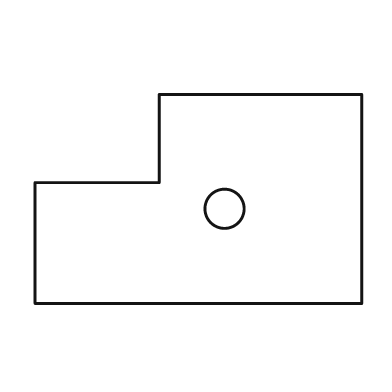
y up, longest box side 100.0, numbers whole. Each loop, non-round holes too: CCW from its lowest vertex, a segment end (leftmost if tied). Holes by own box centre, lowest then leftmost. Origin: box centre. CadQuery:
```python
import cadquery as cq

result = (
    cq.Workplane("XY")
    .moveTo(-50.0, -32.0)
    .lineTo(50.0, -32.0)
    .lineTo(50.0, 32.0)
    .lineTo(-12.0, 32.0)
    .lineTo(-12.0, 5.0)
    .lineTo(-50.0, 5.0)
    .close()
    .moveTo(8.0, -3.0)
    .circle(6.0)
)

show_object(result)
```